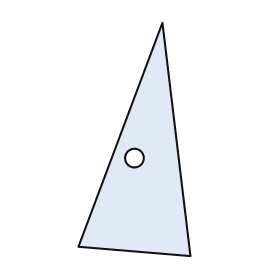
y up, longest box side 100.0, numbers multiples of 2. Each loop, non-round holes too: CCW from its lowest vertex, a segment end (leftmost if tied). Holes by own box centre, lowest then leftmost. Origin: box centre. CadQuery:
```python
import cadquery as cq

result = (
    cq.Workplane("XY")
    .moveTo(24.0, -50.0)
    .lineTo(12.0, 50.0)
    .lineTo(-24.0, -46.0)
    .close()
    .moveTo(0.0, -8.0)
    .circle(4.0)
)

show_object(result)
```